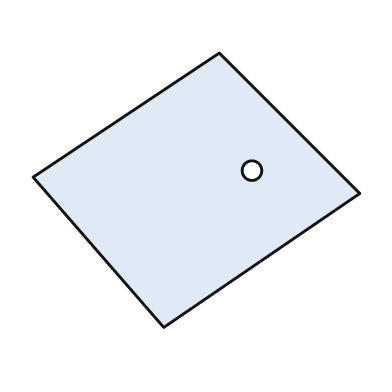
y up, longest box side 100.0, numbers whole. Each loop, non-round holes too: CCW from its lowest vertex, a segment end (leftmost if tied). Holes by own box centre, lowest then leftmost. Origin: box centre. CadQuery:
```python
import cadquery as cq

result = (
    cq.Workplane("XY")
    .moveTo(-10.0, -42.0)
    .lineTo(50.0, -1.0)
    .lineTo(7.0, 42.0)
    .lineTo(-50.0, 4.0)
    .close()
    .moveTo(17.0, 6.0)
    .circle(3.0)
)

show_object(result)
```